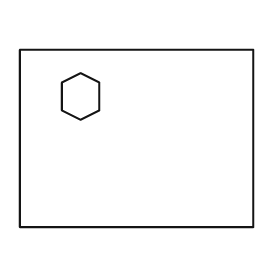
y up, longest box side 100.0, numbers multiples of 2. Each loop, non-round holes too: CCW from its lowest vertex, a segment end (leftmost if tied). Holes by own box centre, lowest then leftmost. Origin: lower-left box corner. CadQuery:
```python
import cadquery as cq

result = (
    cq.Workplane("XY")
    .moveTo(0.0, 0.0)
    .lineTo(100.0, 0.0)
    .lineTo(100.0, 76.0)
    .lineTo(0.0, 76.0)
    .close()
    .moveTo(26.0, 46.0)
    .lineTo(34.0, 50.0)
    .lineTo(34.0, 62.0)
    .lineTo(26.0, 66.0)
    .lineTo(18.0, 62.0)
    .lineTo(18.0, 50.0)
    .close()
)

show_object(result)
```